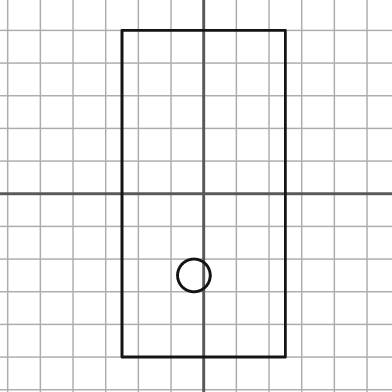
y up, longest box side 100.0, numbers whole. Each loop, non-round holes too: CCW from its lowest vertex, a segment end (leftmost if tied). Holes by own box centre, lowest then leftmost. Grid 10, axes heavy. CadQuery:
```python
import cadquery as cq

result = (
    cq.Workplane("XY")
    .moveTo(-25.0, -50.0)
    .lineTo(25.0, -50.0)
    .lineTo(25.0, 50.0)
    .lineTo(-25.0, 50.0)
    .close()
    .moveTo(-3.0, -25.0)
    .circle(5.0)
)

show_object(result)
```